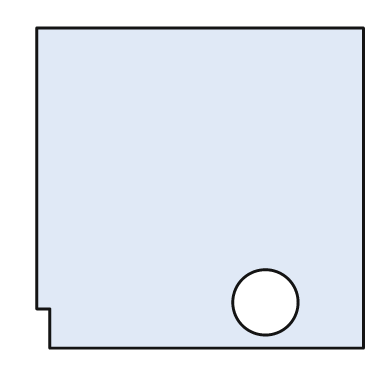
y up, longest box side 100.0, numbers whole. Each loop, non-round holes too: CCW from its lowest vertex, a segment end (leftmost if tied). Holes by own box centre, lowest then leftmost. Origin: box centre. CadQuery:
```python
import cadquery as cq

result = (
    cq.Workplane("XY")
    .moveTo(-46.0, -49.0)
    .lineTo(50.0, -49.0)
    .lineTo(50.0, 49.0)
    .lineTo(-50.0, 49.0)
    .lineTo(-50.0, -37.0)
    .lineTo(-46.0, -37.0)
    .close()
    .moveTo(20.0, -35.0)
    .circle(10.0)
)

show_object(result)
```